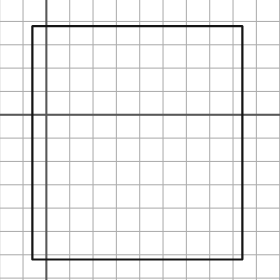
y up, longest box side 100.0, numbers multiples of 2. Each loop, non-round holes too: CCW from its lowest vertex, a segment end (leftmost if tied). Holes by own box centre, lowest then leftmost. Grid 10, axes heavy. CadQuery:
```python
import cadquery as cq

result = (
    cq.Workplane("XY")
    .moveTo(-6.0, -62.0)
    .lineTo(84.0, -62.0)
    .lineTo(84.0, 38.0)
    .lineTo(-6.0, 38.0)
    .close()
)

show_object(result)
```